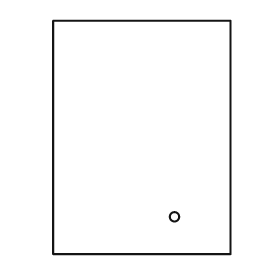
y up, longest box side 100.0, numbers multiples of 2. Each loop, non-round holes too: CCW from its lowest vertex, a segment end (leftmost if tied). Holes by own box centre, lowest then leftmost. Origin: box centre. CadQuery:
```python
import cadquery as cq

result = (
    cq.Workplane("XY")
    .moveTo(-38.0, -50.0)
    .lineTo(38.0, -50.0)
    .lineTo(38.0, 50.0)
    .lineTo(-38.0, 50.0)
    .close()
    .moveTo(14.0, -34.0)
    .circle(2.0)
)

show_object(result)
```